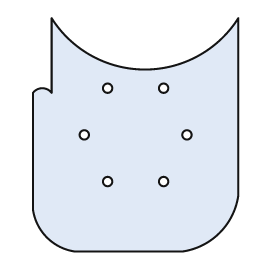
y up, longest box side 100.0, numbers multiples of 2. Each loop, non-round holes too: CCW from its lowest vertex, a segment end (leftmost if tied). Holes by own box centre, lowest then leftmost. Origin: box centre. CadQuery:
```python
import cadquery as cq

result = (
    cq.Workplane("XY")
    .moveTo(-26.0, -50.0)
    .lineTo(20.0, -50.0)
    .threePointArc((36.0, -42.0), (44.0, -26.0))
    .lineTo(44.0, 50.0)
    .threePointArc((4.0, 28.0), (-36.0, 50.0))
    .lineTo(-36.0, 18.0)
    .threePointArc((-40.0, 20.0), (-44.0, 18.0))
    .lineTo(-44.0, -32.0)
    .threePointArc((-38.0, -44.0), (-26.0, -50.0))
    .close()
    .moveTo(-12.0, -20.0)
    .circle(2.0)
    .moveTo(12.0, -20.0)
    .circle(2.0)
    .moveTo(-22.0, 0.0)
    .circle(2.0)
    .moveTo(22.0, 0.0)
    .circle(2.0)
    .moveTo(-12.0, 20.0)
    .circle(2.0)
    .moveTo(12.0, 20.0)
    .circle(2.0)
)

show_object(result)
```